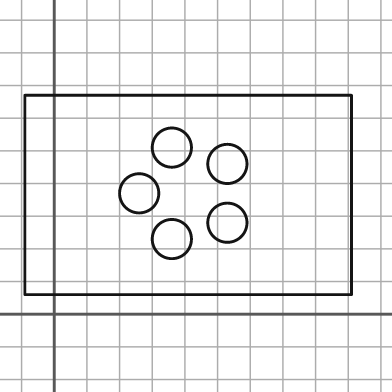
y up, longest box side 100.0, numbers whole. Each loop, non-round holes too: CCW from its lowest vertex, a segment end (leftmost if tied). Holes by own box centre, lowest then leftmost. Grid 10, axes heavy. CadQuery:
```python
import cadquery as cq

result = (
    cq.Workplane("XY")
    .moveTo(-9.0, 6.0)
    .lineTo(91.0, 6.0)
    .lineTo(91.0, 67.0)
    .lineTo(-9.0, 67.0)
    .close()
    .moveTo(36.0, 23.0)
    .circle(6.0)
    .moveTo(53.0, 28.0)
    .circle(6.0)
    .moveTo(26.0, 37.0)
    .circle(6.0)
    .moveTo(53.0, 46.0)
    .circle(6.0)
    .moveTo(36.0, 51.0)
    .circle(6.0)
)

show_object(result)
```